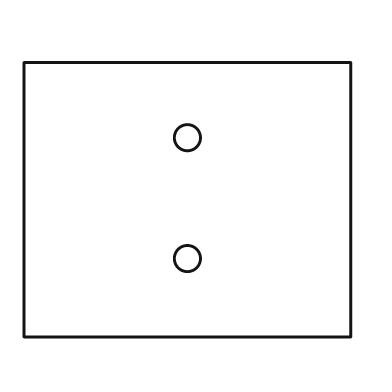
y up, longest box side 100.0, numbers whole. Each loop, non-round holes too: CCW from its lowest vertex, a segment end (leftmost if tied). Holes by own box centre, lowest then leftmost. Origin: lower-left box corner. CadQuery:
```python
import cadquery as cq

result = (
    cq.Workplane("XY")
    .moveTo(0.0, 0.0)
    .lineTo(100.0, 0.0)
    .lineTo(100.0, 84.0)
    .lineTo(0.0, 84.0)
    .close()
    .moveTo(50.0, 24.0)
    .circle(4.0)
    .moveTo(50.0, 61.0)
    .circle(4.0)
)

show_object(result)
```